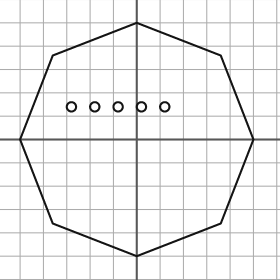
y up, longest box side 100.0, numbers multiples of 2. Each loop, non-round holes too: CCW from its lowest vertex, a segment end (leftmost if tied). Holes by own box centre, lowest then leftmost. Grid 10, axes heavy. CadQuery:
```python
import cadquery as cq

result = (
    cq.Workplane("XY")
    .moveTo(0.0, -50.0)
    .lineTo(36.0, -36.0)
    .lineTo(50.0, 0.0)
    .lineTo(36.0, 36.0)
    .lineTo(0.0, 50.0)
    .lineTo(-36.0, 36.0)
    .lineTo(-50.0, 0.0)
    .lineTo(-36.0, -36.0)
    .close()
    .moveTo(-28.0, 14.0)
    .circle(2.0)
    .moveTo(-18.0, 14.0)
    .circle(2.0)
    .moveTo(-8.0, 14.0)
    .circle(2.0)
    .moveTo(2.0, 14.0)
    .circle(2.0)
    .moveTo(12.0, 14.0)
    .circle(2.0)
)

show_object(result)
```